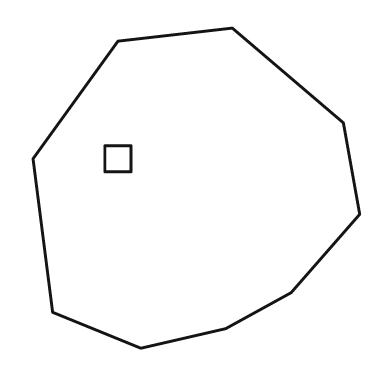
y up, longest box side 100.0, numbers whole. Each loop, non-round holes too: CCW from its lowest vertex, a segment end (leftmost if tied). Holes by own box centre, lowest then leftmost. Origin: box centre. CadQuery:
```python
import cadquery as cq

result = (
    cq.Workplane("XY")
    .moveTo(-17.0, -49.0)
    .lineTo(9.0, -43.0)
    .lineTo(29.0, -32.0)
    .lineTo(50.0, -8.0)
    .lineTo(45.0, 20.0)
    .lineTo(11.0, 49.0)
    .lineTo(-24.0, 45.0)
    .lineTo(-50.0, 9.0)
    .lineTo(-44.0, -38.0)
    .close()
    .moveTo(-28.0, 5.0)
    .lineTo(-20.0, 5.0)
    .lineTo(-20.0, 13.0)
    .lineTo(-28.0, 13.0)
    .close()
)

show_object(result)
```